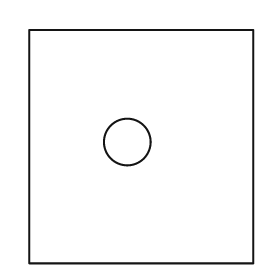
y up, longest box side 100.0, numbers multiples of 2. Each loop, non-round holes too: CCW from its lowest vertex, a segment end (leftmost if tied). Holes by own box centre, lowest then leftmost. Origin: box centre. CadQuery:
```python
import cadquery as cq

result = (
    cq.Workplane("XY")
    .moveTo(-48.0, -50.0)
    .lineTo(48.0, -50.0)
    .lineTo(48.0, 50.0)
    .lineTo(-48.0, 50.0)
    .close()
    .moveTo(-6.0, 2.0)
    .circle(10.0)
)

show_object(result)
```